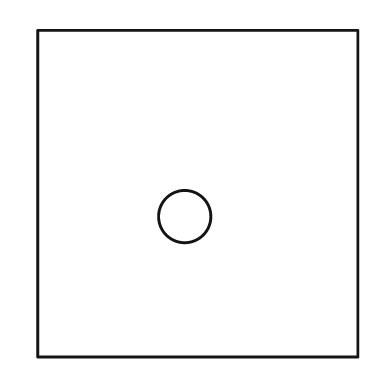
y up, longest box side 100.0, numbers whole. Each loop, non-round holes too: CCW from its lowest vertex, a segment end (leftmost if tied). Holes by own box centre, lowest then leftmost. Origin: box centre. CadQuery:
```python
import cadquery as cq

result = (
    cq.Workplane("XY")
    .moveTo(-49.0, -50.0)
    .lineTo(49.0, -50.0)
    .lineTo(49.0, 50.0)
    .lineTo(-49.0, 50.0)
    .close()
    .moveTo(-4.0, -7.0)
    .circle(8.0)
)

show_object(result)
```